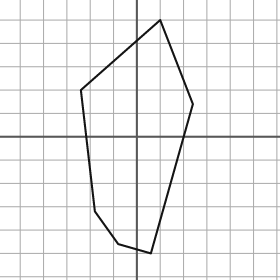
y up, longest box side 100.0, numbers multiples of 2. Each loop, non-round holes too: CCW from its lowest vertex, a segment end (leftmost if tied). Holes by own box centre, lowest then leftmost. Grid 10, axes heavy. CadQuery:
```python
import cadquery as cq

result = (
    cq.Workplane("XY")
    .moveTo(6.0, -50.0)
    .lineTo(24.0, 14.0)
    .lineTo(10.0, 50.0)
    .lineTo(-24.0, 20.0)
    .lineTo(-18.0, -32.0)
    .lineTo(-8.0, -46.0)
    .close()
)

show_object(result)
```